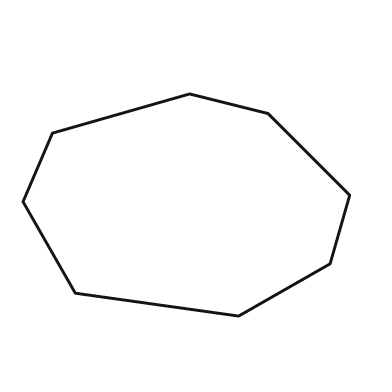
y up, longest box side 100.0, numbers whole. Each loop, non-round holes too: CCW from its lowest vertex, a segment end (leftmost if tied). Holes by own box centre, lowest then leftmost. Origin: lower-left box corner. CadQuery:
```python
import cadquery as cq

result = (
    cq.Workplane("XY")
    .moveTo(66.0, 0.0)
    .lineTo(94.0, 16.0)
    .lineTo(100.0, 37.0)
    .lineTo(75.0, 62.0)
    .lineTo(51.0, 68.0)
    .lineTo(9.0, 56.0)
    .lineTo(0.0, 35.0)
    .lineTo(16.0, 7.0)
    .close()
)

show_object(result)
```